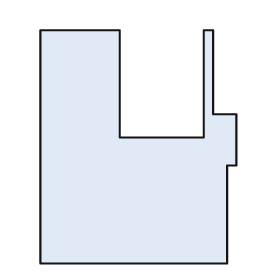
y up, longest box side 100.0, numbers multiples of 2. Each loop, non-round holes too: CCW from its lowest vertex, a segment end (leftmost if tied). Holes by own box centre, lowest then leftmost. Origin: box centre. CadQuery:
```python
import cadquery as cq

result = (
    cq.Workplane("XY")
    .moveTo(-42.0, -50.0)
    .lineTo(38.0, -50.0)
    .lineTo(38.0, -8.0)
    .lineTo(42.0, -8.0)
    .lineTo(42.0, 14.0)
    .lineTo(32.0, 14.0)
    .lineTo(32.0, 50.0)
    .lineTo(28.0, 50.0)
    .lineTo(28.0, 4.0)
    .lineTo(-8.0, 4.0)
    .lineTo(-8.0, 50.0)
    .lineTo(-42.0, 50.0)
    .close()
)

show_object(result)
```